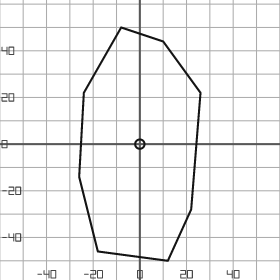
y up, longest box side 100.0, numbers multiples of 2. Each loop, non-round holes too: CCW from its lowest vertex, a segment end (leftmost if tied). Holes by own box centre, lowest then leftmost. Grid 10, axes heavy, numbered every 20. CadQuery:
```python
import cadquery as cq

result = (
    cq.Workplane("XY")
    .moveTo(12.0, -50.0)
    .lineTo(22.0, -28.0)
    .lineTo(26.0, 22.0)
    .lineTo(10.0, 44.0)
    .lineTo(-8.0, 50.0)
    .lineTo(-24.0, 22.0)
    .lineTo(-26.0, -14.0)
    .lineTo(-18.0, -46.0)
    .close()
    .moveTo(0.0, 0.0)
    .circle(2.0)
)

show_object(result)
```